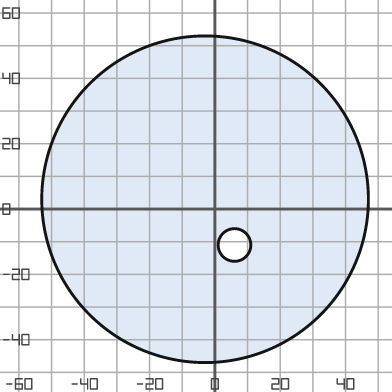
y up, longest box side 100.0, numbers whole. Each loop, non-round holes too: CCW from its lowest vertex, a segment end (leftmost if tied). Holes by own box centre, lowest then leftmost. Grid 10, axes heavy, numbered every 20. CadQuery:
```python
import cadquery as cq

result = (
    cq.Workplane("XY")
    .moveTo(-3.0, 3.0)
    .circle(50.0)
    .moveTo(6.0, -11.0)
    .circle(5.0)
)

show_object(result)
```